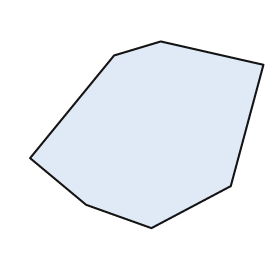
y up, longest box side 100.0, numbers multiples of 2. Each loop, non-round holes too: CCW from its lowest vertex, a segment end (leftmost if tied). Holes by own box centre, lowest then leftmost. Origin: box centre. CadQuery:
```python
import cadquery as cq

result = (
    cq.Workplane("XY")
    .moveTo(2.0, -40.0)
    .lineTo(36.0, -22.0)
    .lineTo(50.0, 30.0)
    .lineTo(6.0, 40.0)
    .lineTo(-14.0, 34.0)
    .lineTo(-50.0, -10.0)
    .lineTo(-26.0, -30.0)
    .close()
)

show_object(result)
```